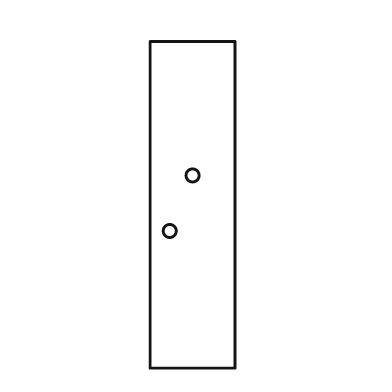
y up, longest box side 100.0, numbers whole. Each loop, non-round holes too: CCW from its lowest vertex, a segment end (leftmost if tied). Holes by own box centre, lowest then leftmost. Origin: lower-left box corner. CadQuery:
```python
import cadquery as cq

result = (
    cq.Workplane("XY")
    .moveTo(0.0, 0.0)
    .lineTo(26.0, 0.0)
    .lineTo(26.0, 100.0)
    .lineTo(0.0, 100.0)
    .close()
    .moveTo(6.0, 42.0)
    .circle(2.0)
    .moveTo(13.0, 59.0)
    .circle(2.0)
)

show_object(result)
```